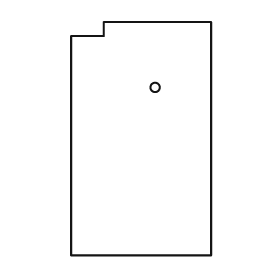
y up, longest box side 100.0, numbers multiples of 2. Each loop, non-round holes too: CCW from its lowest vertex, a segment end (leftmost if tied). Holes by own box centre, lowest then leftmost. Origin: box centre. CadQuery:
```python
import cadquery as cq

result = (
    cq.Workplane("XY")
    .moveTo(-30.0, -50.0)
    .lineTo(30.0, -50.0)
    .lineTo(30.0, 50.0)
    .lineTo(-16.0, 50.0)
    .lineTo(-16.0, 44.0)
    .lineTo(-30.0, 44.0)
    .close()
    .moveTo(6.0, 22.0)
    .circle(2.0)
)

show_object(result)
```